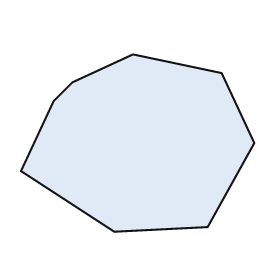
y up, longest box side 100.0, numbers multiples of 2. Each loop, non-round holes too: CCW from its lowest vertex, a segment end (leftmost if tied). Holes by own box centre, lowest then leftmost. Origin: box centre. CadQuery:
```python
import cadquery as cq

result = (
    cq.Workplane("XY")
    .moveTo(-10.0, -38.0)
    .lineTo(30.0, -36.0)
    .lineTo(50.0, 0.0)
    .lineTo(36.0, 30.0)
    .lineTo(-2.0, 38.0)
    .lineTo(-28.0, 26.0)
    .lineTo(-36.0, 18.0)
    .lineTo(-50.0, -12.0)
    .close()
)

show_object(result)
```